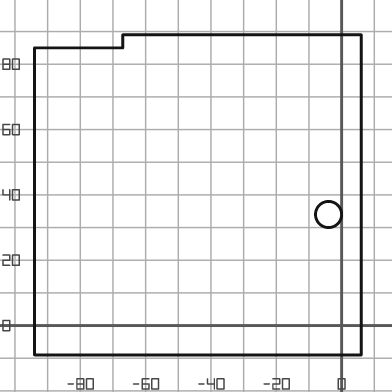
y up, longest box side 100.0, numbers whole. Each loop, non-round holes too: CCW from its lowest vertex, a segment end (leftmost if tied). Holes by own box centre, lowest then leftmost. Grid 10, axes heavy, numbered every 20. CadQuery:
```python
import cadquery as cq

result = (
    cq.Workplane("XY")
    .moveTo(-94.0, -9.0)
    .lineTo(6.0, -9.0)
    .lineTo(6.0, 89.0)
    .lineTo(-67.0, 89.0)
    .lineTo(-67.0, 85.0)
    .lineTo(-94.0, 85.0)
    .close()
    .moveTo(-4.0, 34.0)
    .circle(4.0)
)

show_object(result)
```